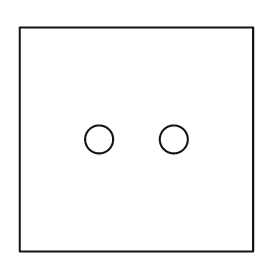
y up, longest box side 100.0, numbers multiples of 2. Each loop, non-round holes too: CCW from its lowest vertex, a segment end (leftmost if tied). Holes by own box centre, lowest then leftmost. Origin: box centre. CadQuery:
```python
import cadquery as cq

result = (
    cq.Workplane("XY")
    .moveTo(-50.0, -48.0)
    .lineTo(50.0, -48.0)
    .lineTo(50.0, 48.0)
    .lineTo(-50.0, 48.0)
    .close()
    .moveTo(-16.0, 0.0)
    .circle(6.0)
    .moveTo(16.0, 0.0)
    .circle(6.0)
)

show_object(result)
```